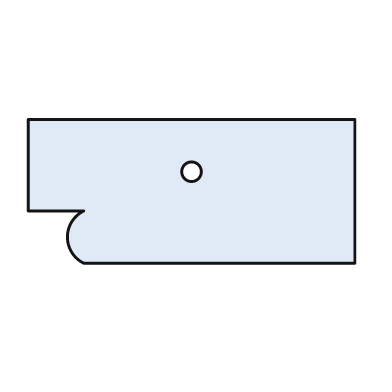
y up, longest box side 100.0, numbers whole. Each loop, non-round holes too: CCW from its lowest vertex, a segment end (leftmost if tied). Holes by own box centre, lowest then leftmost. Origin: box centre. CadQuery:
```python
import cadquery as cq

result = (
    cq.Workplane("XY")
    .moveTo(-33.0, -22.0)
    .lineTo(50.0, -22.0)
    .lineTo(50.0, 22.0)
    .lineTo(-50.0, 22.0)
    .lineTo(-50.0, -6.0)
    .lineTo(-33.0, -6.0)
    .threePointArc((-38.0, -14.0), (-33.0, -22.0))
    .close()
    .moveTo(0.0, 6.0)
    .circle(3.0)
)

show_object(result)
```